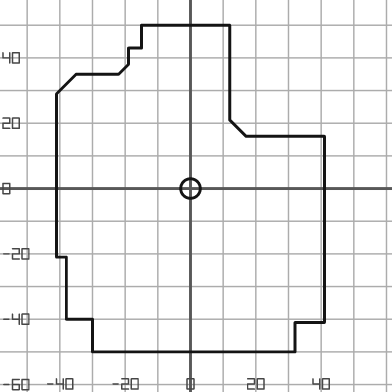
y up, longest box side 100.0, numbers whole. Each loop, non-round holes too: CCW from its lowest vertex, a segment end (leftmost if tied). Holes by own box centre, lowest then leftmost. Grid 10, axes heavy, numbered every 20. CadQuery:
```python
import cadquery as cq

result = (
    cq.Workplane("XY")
    .moveTo(-30.0, -50.0)
    .lineTo(32.0, -50.0)
    .lineTo(32.0, -41.0)
    .lineTo(41.0, -41.0)
    .lineTo(41.0, 16.0)
    .lineTo(17.0, 16.0)
    .lineTo(12.0, 21.0)
    .lineTo(12.0, 50.0)
    .lineTo(-15.0, 50.0)
    .lineTo(-15.0, 43.0)
    .lineTo(-19.0, 43.0)
    .lineTo(-19.0, 38.0)
    .lineTo(-22.0, 35.0)
    .lineTo(-35.0, 35.0)
    .lineTo(-41.0, 29.0)
    .lineTo(-41.0, -21.0)
    .lineTo(-38.0, -21.0)
    .lineTo(-38.0, -40.0)
    .lineTo(-30.0, -40.0)
    .close()
    .moveTo(0.0, 0.0)
    .circle(3.0)
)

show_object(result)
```